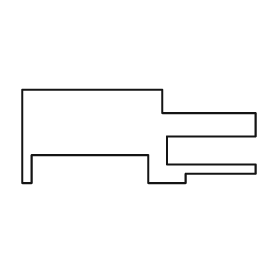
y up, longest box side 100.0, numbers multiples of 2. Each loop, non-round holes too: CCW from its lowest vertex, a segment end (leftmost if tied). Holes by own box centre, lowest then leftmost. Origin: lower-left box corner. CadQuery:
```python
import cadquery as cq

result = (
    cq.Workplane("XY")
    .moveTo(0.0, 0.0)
    .lineTo(4.0, 0.0)
    .lineTo(4.0, 12.0)
    .lineTo(54.0, 12.0)
    .lineTo(54.0, 0.0)
    .lineTo(70.0, 0.0)
    .lineTo(70.0, 4.0)
    .lineTo(100.0, 4.0)
    .lineTo(100.0, 8.0)
    .lineTo(62.0, 8.0)
    .lineTo(62.0, 20.0)
    .lineTo(100.0, 20.0)
    .lineTo(100.0, 30.0)
    .lineTo(60.0, 30.0)
    .lineTo(60.0, 40.0)
    .lineTo(0.0, 40.0)
    .close()
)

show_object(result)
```